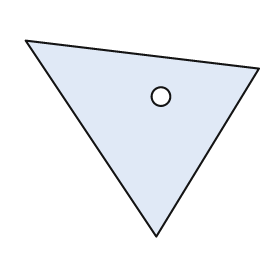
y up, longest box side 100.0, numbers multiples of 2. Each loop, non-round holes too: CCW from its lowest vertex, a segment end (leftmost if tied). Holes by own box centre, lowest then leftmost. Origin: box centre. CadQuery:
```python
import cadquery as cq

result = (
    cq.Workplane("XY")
    .moveTo(6.0, -42.0)
    .lineTo(50.0, 30.0)
    .lineTo(-50.0, 42.0)
    .close()
    .moveTo(8.0, 18.0)
    .circle(4.0)
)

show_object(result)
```